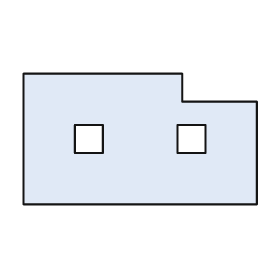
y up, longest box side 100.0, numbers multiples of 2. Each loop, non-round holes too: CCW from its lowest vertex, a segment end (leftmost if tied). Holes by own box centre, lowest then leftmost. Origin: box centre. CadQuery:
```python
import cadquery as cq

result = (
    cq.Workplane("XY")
    .moveTo(-50.0, -28.0)
    .lineTo(50.0, -28.0)
    .lineTo(50.0, 16.0)
    .lineTo(18.0, 16.0)
    .lineTo(18.0, 28.0)
    .lineTo(-50.0, 28.0)
    .close()
    .moveTo(-28.0, -6.0)
    .lineTo(-16.0, -6.0)
    .lineTo(-16.0, 6.0)
    .lineTo(-28.0, 6.0)
    .close()
    .moveTo(16.0, -6.0)
    .lineTo(28.0, -6.0)
    .lineTo(28.0, 6.0)
    .lineTo(16.0, 6.0)
    .close()
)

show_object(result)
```